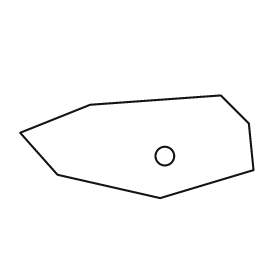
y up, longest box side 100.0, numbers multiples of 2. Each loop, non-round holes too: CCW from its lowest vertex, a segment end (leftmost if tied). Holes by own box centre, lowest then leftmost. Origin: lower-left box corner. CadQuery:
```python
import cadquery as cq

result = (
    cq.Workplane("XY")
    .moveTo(60.0, 0.0)
    .lineTo(100.0, 12.0)
    .lineTo(98.0, 32.0)
    .lineTo(86.0, 44.0)
    .lineTo(30.0, 40.0)
    .lineTo(0.0, 28.0)
    .lineTo(16.0, 10.0)
    .close()
    .moveTo(62.0, 18.0)
    .circle(4.0)
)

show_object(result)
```